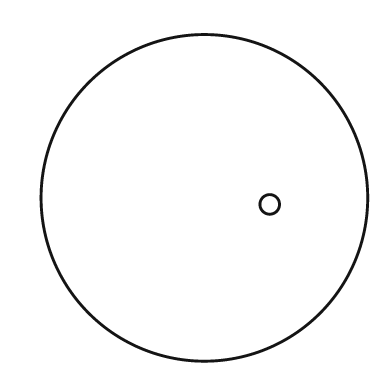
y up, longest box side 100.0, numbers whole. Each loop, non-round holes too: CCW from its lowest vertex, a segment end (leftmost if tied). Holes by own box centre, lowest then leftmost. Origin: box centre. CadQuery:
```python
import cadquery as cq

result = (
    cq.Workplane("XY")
    .moveTo(0.0, 0.0)
    .circle(50.0)
    .moveTo(20.0, -2.0)
    .circle(3.0)
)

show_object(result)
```